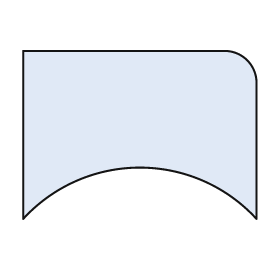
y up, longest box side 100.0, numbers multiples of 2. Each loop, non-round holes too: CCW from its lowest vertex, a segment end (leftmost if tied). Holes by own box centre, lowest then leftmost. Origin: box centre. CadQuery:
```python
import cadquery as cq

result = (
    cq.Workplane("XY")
    .moveTo(-50.0, -36.0)
    .threePointArc((0.0, -14.0), (50.0, -36.0))
    .lineTo(50.0, 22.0)
    .threePointArc((46.0, 32.0), (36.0, 36.0))
    .lineTo(-50.0, 36.0)
    .close()
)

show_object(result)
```